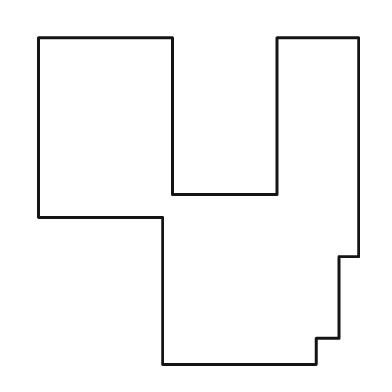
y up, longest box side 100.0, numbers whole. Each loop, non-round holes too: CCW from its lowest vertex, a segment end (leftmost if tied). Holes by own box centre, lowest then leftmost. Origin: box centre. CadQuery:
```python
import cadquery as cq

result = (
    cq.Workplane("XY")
    .moveTo(-11.0, -50.0)
    .lineTo(36.0, -50.0)
    .lineTo(36.0, -42.0)
    .lineTo(43.0, -42.0)
    .lineTo(43.0, -17.0)
    .lineTo(49.0, -17.0)
    .lineTo(49.0, 50.0)
    .lineTo(24.0, 50.0)
    .lineTo(24.0, 2.0)
    .lineTo(-8.0, 2.0)
    .lineTo(-8.0, 50.0)
    .lineTo(-49.0, 50.0)
    .lineTo(-49.0, -5.0)
    .lineTo(-11.0, -5.0)
    .close()
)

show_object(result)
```